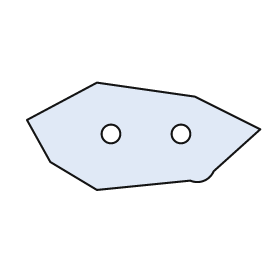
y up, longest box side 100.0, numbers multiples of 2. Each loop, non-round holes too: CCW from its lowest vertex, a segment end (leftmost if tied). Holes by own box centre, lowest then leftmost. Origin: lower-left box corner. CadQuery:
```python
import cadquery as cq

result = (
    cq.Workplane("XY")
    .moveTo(30.0, 0.0)
    .lineTo(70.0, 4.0)
    .threePointArc((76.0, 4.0), (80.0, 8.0))
    .lineTo(100.0, 26.0)
    .lineTo(72.0, 40.0)
    .lineTo(30.0, 46.0)
    .lineTo(0.0, 30.0)
    .lineTo(10.0, 12.0)
    .close()
    .moveTo(36.0, 24.0)
    .circle(4.0)
    .moveTo(66.0, 24.0)
    .circle(4.0)
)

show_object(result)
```